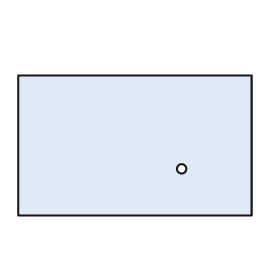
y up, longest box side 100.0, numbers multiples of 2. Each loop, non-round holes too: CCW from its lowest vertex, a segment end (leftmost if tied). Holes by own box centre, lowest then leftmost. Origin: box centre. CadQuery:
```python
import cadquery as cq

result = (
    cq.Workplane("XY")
    .moveTo(-50.0, -30.0)
    .lineTo(50.0, -30.0)
    .lineTo(50.0, 30.0)
    .lineTo(-50.0, 30.0)
    .close()
    .moveTo(20.0, -10.0)
    .circle(2.0)
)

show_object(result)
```